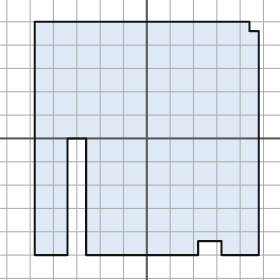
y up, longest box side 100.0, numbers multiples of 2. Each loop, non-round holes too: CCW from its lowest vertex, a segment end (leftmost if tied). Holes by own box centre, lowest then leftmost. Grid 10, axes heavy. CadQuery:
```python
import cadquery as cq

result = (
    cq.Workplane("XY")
    .moveTo(-48.0, -50.0)
    .lineTo(-34.0, -50.0)
    .lineTo(-34.0, 0.0)
    .lineTo(-26.0, 0.0)
    .lineTo(-26.0, -50.0)
    .lineTo(22.0, -50.0)
    .lineTo(22.0, -44.0)
    .lineTo(32.0, -44.0)
    .lineTo(32.0, -50.0)
    .lineTo(48.0, -50.0)
    .lineTo(48.0, 46.0)
    .lineTo(44.0, 46.0)
    .lineTo(44.0, 50.0)
    .lineTo(-48.0, 50.0)
    .close()
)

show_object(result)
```